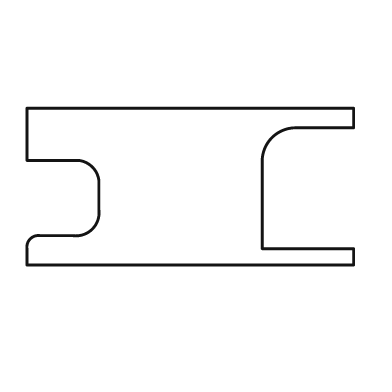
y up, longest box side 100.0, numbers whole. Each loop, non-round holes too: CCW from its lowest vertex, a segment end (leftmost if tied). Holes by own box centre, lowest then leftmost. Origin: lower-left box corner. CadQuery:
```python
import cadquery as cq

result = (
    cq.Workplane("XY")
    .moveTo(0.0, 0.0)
    .lineTo(100.0, 0.0)
    .lineTo(100.0, 5.0)
    .lineTo(72.0, 5.0)
    .lineTo(72.0, 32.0)
    .threePointArc((75.0, 39.0), (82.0, 42.0))
    .lineTo(100.0, 42.0)
    .lineTo(100.0, 48.0)
    .lineTo(0.0, 48.0)
    .lineTo(0.0, 32.0)
    .lineTo(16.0, 32.0)
    .threePointArc((20.0, 30.0), (22.0, 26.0))
    .lineTo(22.0, 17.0)
    .threePointArc((20.0, 11.0), (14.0, 9.0))
    .lineTo(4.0, 9.0)
    .threePointArc((1.0, 8.0), (0.0, 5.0))
    .close()
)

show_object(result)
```